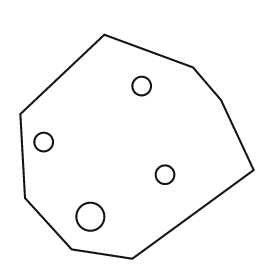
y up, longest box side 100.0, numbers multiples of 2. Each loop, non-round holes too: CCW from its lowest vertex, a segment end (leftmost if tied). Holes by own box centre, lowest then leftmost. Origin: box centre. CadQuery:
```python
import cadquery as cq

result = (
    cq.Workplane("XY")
    .moveTo(-2.0, -48.0)
    .lineTo(50.0, -10.0)
    .lineTo(36.0, 20.0)
    .lineTo(24.0, 34.0)
    .lineTo(-14.0, 48.0)
    .lineTo(-50.0, 14.0)
    .lineTo(-48.0, -22.0)
    .lineTo(-28.0, -44.0)
    .close()
    .moveTo(-20.0, -30.0)
    .circle(6.0)
    .moveTo(12.0, -12.0)
    .circle(4.0)
    .moveTo(-40.0, 2.0)
    .circle(4.0)
    .moveTo(2.0, 26.0)
    .circle(4.0)
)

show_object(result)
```